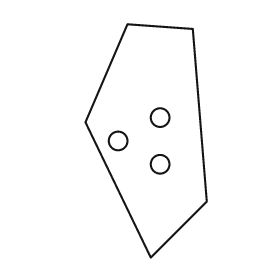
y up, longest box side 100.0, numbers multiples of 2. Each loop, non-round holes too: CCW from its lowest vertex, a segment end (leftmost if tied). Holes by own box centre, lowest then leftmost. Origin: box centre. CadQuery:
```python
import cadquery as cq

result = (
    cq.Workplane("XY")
    .moveTo(2.0, -50.0)
    .lineTo(26.0, -26.0)
    .lineTo(20.0, 48.0)
    .lineTo(-8.0, 50.0)
    .lineTo(-26.0, 8.0)
    .close()
    .moveTo(6.0, -10.0)
    .circle(4.0)
    .moveTo(-12.0, 0.0)
    .circle(4.0)
    .moveTo(6.0, 10.0)
    .circle(4.0)
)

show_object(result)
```